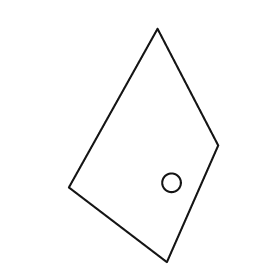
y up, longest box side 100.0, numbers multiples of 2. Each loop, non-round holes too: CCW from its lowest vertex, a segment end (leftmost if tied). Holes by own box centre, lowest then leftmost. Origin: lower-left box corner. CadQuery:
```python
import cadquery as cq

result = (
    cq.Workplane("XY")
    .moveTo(42.0, 0.0)
    .lineTo(64.0, 50.0)
    .lineTo(38.0, 100.0)
    .lineTo(0.0, 32.0)
    .close()
    .moveTo(44.0, 34.0)
    .circle(4.0)
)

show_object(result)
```